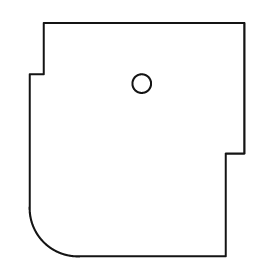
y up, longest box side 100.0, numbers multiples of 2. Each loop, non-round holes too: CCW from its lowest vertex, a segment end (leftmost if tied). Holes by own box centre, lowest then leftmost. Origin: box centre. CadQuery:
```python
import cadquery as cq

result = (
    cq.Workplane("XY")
    .moveTo(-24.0, -50.0)
    .lineTo(38.0, -50.0)
    .lineTo(38.0, -6.0)
    .lineTo(46.0, -6.0)
    .lineTo(46.0, 50.0)
    .lineTo(-40.0, 50.0)
    .lineTo(-40.0, 28.0)
    .lineTo(-46.0, 28.0)
    .lineTo(-46.0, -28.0)
    .threePointArc((-40.0, -44.0), (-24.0, -50.0))
    .close()
    .moveTo(2.0, 24.0)
    .circle(4.0)
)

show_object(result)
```